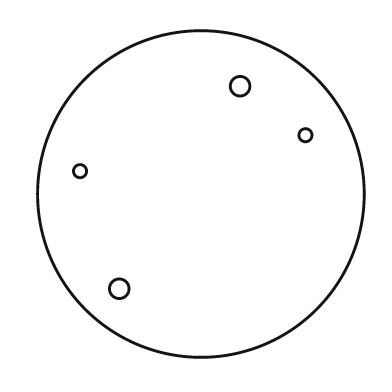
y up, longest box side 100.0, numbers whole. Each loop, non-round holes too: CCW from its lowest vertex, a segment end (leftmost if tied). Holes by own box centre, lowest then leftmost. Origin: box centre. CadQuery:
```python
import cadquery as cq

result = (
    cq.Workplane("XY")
    .moveTo(0.0, 0.0)
    .circle(50.0)
    .moveTo(-25.0, -29.0)
    .circle(3.0)
    .moveTo(-37.0, 7.0)
    .circle(2.0)
    .moveTo(32.0, 18.0)
    .circle(2.0)
    .moveTo(12.0, 33.0)
    .circle(3.0)
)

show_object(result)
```